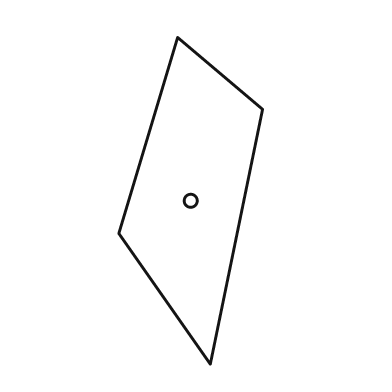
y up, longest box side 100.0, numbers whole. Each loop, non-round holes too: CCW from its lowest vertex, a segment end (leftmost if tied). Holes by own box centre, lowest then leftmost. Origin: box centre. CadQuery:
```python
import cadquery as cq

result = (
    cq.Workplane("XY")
    .moveTo(6.0, -50.0)
    .lineTo(22.0, 28.0)
    .lineTo(-4.0, 50.0)
    .lineTo(-22.0, -10.0)
    .close()
    .moveTo(0.0, 0.0)
    .circle(2.0)
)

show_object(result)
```